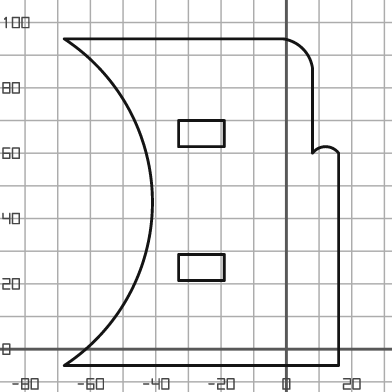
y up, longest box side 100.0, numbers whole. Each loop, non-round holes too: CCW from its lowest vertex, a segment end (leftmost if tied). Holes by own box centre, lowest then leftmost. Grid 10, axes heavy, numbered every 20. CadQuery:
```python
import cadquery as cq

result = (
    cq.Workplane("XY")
    .moveTo(-68.0, -5.0)
    .lineTo(16.0, -5.0)
    .lineTo(16.0, 60.0)
    .threePointArc((12.0, 62.0), (8.0, 60.0))
    .lineTo(8.0, 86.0)
    .threePointArc((5.0, 92.0), (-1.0, 95.0))
    .lineTo(-68.0, 95.0)
    .threePointArc((-41.0, 45.0), (-68.0, -5.0))
    .close()
    .moveTo(-33.0, 21.0)
    .lineTo(-19.0, 21.0)
    .lineTo(-19.0, 29.0)
    .lineTo(-33.0, 29.0)
    .close()
    .moveTo(-33.0, 62.0)
    .lineTo(-19.0, 62.0)
    .lineTo(-19.0, 70.0)
    .lineTo(-33.0, 70.0)
    .close()
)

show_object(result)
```